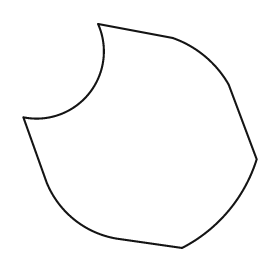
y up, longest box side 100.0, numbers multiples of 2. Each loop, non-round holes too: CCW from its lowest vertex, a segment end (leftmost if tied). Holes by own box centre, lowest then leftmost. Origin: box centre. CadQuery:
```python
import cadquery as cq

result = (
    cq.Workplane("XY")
    .moveTo(18.0, -48.0)
    .threePointArc((38.0, -32.0), (50.0, -10.0))
    .lineTo(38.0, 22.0)
    .threePointArc((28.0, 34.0), (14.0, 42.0))
    .lineTo(-18.0, 48.0)
    .threePointArc((-22.0, 18.0), (-50.0, 8.0))
    .lineTo(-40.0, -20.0)
    .threePointArc((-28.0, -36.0), (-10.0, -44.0))
    .close()
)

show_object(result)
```